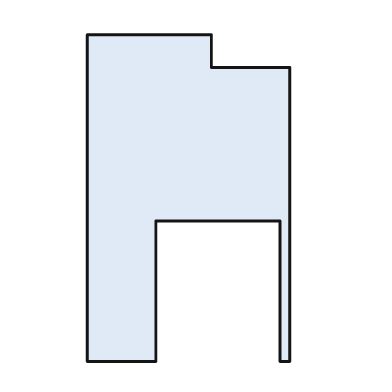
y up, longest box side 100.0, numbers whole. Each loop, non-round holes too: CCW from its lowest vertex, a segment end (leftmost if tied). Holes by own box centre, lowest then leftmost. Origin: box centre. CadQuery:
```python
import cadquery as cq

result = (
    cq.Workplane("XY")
    .moveTo(-31.0, -50.0)
    .lineTo(-10.0, -50.0)
    .lineTo(-10.0, -7.0)
    .lineTo(28.0, -7.0)
    .lineTo(28.0, -50.0)
    .lineTo(31.0, -50.0)
    .lineTo(31.0, 40.0)
    .lineTo(7.0, 40.0)
    .lineTo(7.0, 50.0)
    .lineTo(-31.0, 50.0)
    .close()
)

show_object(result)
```